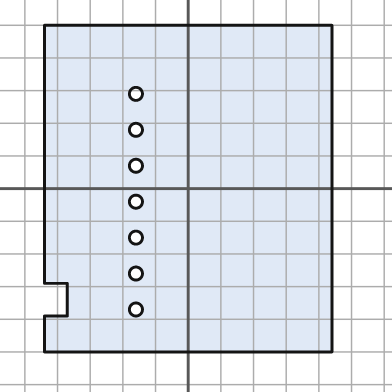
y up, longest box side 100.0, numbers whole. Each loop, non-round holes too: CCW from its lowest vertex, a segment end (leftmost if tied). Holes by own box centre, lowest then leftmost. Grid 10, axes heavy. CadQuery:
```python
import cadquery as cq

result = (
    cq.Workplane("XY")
    .moveTo(-44.0, -50.0)
    .lineTo(44.0, -50.0)
    .lineTo(44.0, 50.0)
    .lineTo(-44.0, 50.0)
    .lineTo(-44.0, -29.0)
    .lineTo(-37.0, -29.0)
    .lineTo(-37.0, -39.0)
    .lineTo(-44.0, -39.0)
    .close()
    .moveTo(-16.0, -37.0)
    .circle(2.0)
    .moveTo(-16.0, -26.0)
    .circle(2.0)
    .moveTo(-16.0, -15.0)
    .circle(2.0)
    .moveTo(-16.0, -4.0)
    .circle(2.0)
    .moveTo(-16.0, 7.0)
    .circle(2.0)
    .moveTo(-16.0, 18.0)
    .circle(2.0)
    .moveTo(-16.0, 29.0)
    .circle(2.0)
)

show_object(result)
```